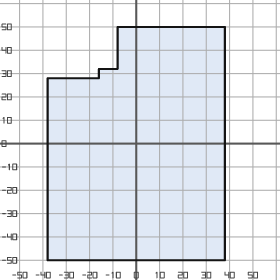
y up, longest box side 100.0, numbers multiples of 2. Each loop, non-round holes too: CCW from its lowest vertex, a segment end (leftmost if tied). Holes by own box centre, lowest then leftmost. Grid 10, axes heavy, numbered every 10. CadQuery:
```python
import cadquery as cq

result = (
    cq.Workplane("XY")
    .moveTo(-38.0, -50.0)
    .lineTo(38.0, -50.0)
    .lineTo(38.0, 50.0)
    .lineTo(-8.0, 50.0)
    .lineTo(-8.0, 32.0)
    .lineTo(-16.0, 32.0)
    .lineTo(-16.0, 28.0)
    .lineTo(-38.0, 28.0)
    .close()
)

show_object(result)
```